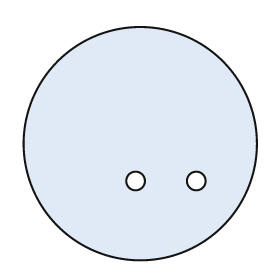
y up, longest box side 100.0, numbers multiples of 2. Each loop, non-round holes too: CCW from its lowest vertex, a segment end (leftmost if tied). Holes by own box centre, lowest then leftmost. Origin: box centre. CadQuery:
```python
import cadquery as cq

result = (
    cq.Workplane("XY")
    .moveTo(0.0, 0.0)
    .circle(50.0)
    .moveTo(-2.0, -16.0)
    .circle(4.0)
    .moveTo(24.0, -16.0)
    .circle(4.0)
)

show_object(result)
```